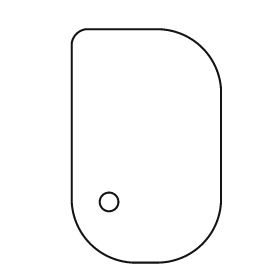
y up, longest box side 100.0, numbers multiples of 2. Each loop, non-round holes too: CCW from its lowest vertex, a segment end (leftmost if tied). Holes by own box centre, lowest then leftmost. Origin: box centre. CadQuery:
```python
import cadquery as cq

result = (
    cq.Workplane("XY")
    .moveTo(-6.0, -50.0)
    .lineTo(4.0, -50.0)
    .threePointArc((24.0, -42.0), (32.0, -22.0))
    .lineTo(32.0, 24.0)
    .threePointArc((24.0, 42.0), (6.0, 50.0))
    .lineTo(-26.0, 50.0)
    .threePointArc((-30.0, 48.0), (-32.0, 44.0))
    .lineTo(-32.0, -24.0)
    .threePointArc((-24.0, -42.0), (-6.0, -50.0))
    .close()
    .moveTo(-16.0, -24.0)
    .circle(4.0)
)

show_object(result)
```